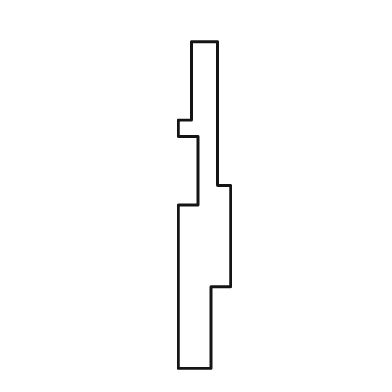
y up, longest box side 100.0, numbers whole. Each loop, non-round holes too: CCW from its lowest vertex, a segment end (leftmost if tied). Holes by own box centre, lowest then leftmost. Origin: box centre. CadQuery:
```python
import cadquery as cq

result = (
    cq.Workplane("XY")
    .moveTo(-8.0, -50.0)
    .lineTo(2.0, -50.0)
    .lineTo(2.0, -25.0)
    .lineTo(8.0, -25.0)
    .lineTo(8.0, 6.0)
    .lineTo(4.0, 6.0)
    .lineTo(4.0, 50.0)
    .lineTo(-4.0, 50.0)
    .lineTo(-4.0, 26.0)
    .lineTo(-8.0, 26.0)
    .lineTo(-8.0, 21.0)
    .lineTo(-2.0, 21.0)
    .lineTo(-2.0, 0.0)
    .lineTo(-8.0, 0.0)
    .close()
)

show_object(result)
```